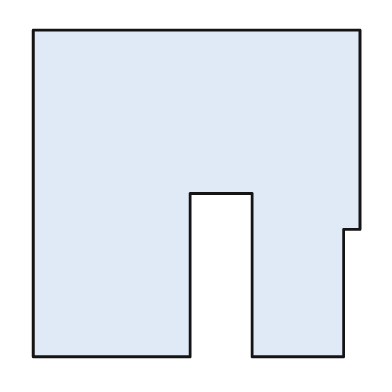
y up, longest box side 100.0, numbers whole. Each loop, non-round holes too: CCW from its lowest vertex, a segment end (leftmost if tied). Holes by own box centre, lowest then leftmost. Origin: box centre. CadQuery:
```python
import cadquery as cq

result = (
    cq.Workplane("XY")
    .moveTo(-50.0, -50.0)
    .lineTo(-2.0, -50.0)
    .lineTo(-2.0, 0.0)
    .lineTo(17.0, 0.0)
    .lineTo(17.0, -50.0)
    .lineTo(45.0, -50.0)
    .lineTo(45.0, -11.0)
    .lineTo(50.0, -11.0)
    .lineTo(50.0, 50.0)
    .lineTo(-50.0, 50.0)
    .close()
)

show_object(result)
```